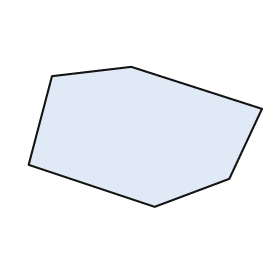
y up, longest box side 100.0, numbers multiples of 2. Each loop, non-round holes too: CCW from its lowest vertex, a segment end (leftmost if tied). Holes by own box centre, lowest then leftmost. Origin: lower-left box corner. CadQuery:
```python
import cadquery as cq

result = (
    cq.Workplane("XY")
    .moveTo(54.0, 0.0)
    .lineTo(86.0, 12.0)
    .lineTo(100.0, 42.0)
    .lineTo(44.0, 60.0)
    .lineTo(10.0, 56.0)
    .lineTo(0.0, 18.0)
    .close()
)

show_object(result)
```